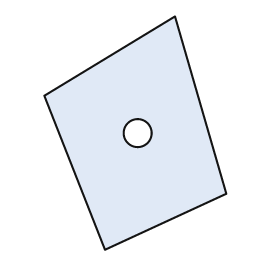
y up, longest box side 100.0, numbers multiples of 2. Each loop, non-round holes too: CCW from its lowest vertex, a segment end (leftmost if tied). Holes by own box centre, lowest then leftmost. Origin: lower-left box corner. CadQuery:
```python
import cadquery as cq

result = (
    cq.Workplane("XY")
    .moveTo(26.0, 0.0)
    .lineTo(78.0, 24.0)
    .lineTo(56.0, 100.0)
    .lineTo(0.0, 66.0)
    .close()
    .moveTo(40.0, 50.0)
    .circle(6.0)
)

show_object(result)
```